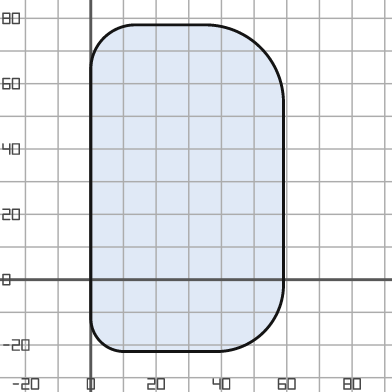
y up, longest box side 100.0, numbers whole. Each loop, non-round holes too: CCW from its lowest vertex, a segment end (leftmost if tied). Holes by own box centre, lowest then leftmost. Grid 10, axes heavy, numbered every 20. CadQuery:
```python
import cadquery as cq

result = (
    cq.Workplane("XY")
    .moveTo(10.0, -22.0)
    .lineTo(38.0, -22.0)
    .threePointArc((53.0, -16.0), (59.0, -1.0))
    .lineTo(59.0, 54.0)
    .threePointArc((52.0, 71.0), (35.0, 78.0))
    .lineTo(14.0, 78.0)
    .threePointArc((4.0, 74.0), (0.0, 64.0))
    .lineTo(0.0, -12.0)
    .threePointArc((3.0, -19.0), (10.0, -22.0))
    .close()
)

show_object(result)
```